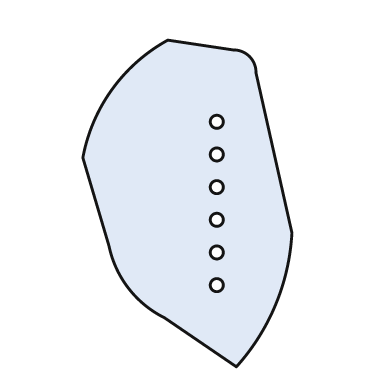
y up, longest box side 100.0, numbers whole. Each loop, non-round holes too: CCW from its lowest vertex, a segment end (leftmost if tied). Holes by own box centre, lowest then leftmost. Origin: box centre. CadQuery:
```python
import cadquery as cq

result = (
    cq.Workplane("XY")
    .moveTo(15.0, -50.0)
    .threePointArc((27.0, -31.0), (32.0, -9.0))
    .lineTo(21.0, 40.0)
    .threePointArc((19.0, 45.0), (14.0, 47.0))
    .lineTo(-6.0, 50.0)
    .threePointArc((-23.0, 35.0), (-32.0, 14.0))
    .lineTo(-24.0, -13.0)
    .threePointArc((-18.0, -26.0), (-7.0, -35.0))
    .close()
    .moveTo(9.0, -25.0)
    .circle(2.0)
    .moveTo(9.0, -15.0)
    .circle(2.0)
    .moveTo(9.0, -5.0)
    .circle(2.0)
    .moveTo(9.0, 5.0)
    .circle(2.0)
    .moveTo(9.0, 15.0)
    .circle(2.0)
    .moveTo(9.0, 25.0)
    .circle(2.0)
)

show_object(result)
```